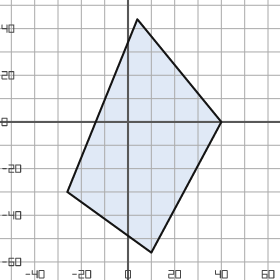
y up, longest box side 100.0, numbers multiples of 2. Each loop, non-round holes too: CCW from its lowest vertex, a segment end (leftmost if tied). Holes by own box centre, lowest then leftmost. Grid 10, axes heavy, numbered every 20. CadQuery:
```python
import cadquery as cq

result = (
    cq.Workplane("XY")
    .moveTo(10.0, -56.0)
    .lineTo(40.0, 0.0)
    .lineTo(4.0, 44.0)
    .lineTo(-26.0, -30.0)
    .close()
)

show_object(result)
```